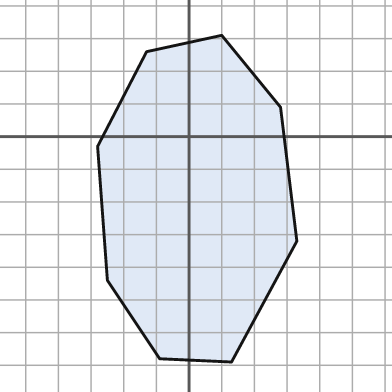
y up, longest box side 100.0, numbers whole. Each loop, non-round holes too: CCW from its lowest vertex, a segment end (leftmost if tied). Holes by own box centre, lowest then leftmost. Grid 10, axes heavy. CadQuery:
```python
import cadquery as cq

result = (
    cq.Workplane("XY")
    .moveTo(13.0, -69.0)
    .lineTo(33.0, -32.0)
    .lineTo(28.0, 9.0)
    .lineTo(10.0, 31.0)
    .lineTo(-13.0, 26.0)
    .lineTo(-28.0, -3.0)
    .lineTo(-25.0, -44.0)
    .lineTo(-9.0, -68.0)
    .close()
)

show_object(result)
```